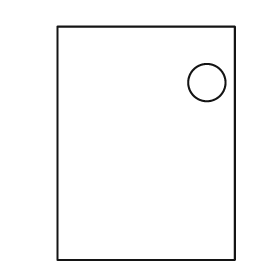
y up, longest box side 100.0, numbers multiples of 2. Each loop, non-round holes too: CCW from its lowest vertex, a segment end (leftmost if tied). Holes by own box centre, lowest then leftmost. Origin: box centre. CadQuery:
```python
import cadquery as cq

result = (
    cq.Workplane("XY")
    .moveTo(-38.0, -50.0)
    .lineTo(38.0, -50.0)
    .lineTo(38.0, 50.0)
    .lineTo(-38.0, 50.0)
    .close()
    .moveTo(26.0, 26.0)
    .circle(8.0)
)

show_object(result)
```